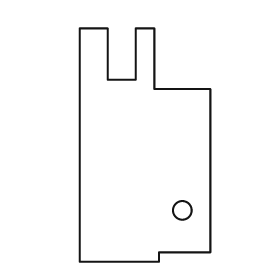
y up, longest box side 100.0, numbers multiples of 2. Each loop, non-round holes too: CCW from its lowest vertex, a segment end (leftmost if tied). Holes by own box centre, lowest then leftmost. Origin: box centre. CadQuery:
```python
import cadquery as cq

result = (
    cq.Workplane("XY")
    .moveTo(-28.0, -50.0)
    .lineTo(6.0, -50.0)
    .lineTo(6.0, -46.0)
    .lineTo(28.0, -46.0)
    .lineTo(28.0, 24.0)
    .lineTo(4.0, 24.0)
    .lineTo(4.0, 50.0)
    .lineTo(-4.0, 50.0)
    .lineTo(-4.0, 28.0)
    .lineTo(-16.0, 28.0)
    .lineTo(-16.0, 50.0)
    .lineTo(-28.0, 50.0)
    .close()
    .moveTo(16.0, -28.0)
    .circle(4.0)
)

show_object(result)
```